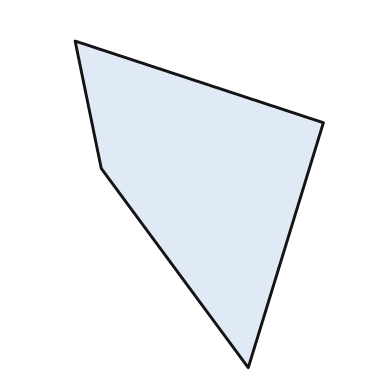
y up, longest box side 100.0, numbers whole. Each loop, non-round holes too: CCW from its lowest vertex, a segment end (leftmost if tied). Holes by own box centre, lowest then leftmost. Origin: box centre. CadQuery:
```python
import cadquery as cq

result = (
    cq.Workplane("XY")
    .moveTo(15.0, -50.0)
    .lineTo(38.0, 25.0)
    .lineTo(-38.0, 50.0)
    .lineTo(-30.0, 11.0)
    .close()
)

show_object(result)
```